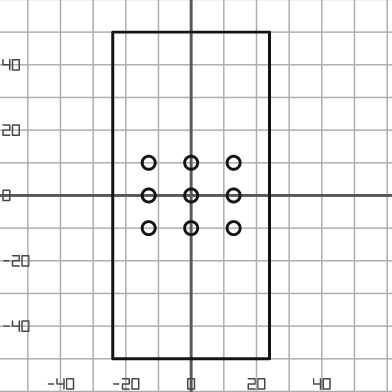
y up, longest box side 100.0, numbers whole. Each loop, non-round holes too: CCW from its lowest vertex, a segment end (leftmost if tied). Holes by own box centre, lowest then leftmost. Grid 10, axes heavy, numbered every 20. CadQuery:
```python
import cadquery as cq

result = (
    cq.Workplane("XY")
    .moveTo(-24.0, -50.0)
    .lineTo(24.0, -50.0)
    .lineTo(24.0, 50.0)
    .lineTo(-24.0, 50.0)
    .close()
    .moveTo(-13.0, -10.0)
    .circle(2.0)
    .moveTo(0.0, -10.0)
    .circle(2.0)
    .moveTo(13.0, -10.0)
    .circle(2.0)
    .moveTo(-13.0, 0.0)
    .circle(2.0)
    .moveTo(0.0, 0.0)
    .circle(2.0)
    .moveTo(13.0, 0.0)
    .circle(2.0)
    .moveTo(-13.0, 10.0)
    .circle(2.0)
    .moveTo(0.0, 10.0)
    .circle(2.0)
    .moveTo(13.0, 10.0)
    .circle(2.0)
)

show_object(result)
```